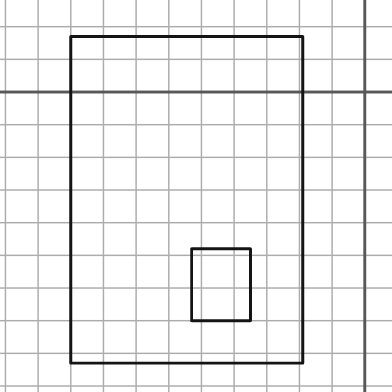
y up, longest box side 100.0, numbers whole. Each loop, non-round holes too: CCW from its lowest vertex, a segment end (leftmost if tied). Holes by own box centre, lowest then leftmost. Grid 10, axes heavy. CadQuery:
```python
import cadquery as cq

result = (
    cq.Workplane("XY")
    .moveTo(-90.0, -83.0)
    .lineTo(-19.0, -83.0)
    .lineTo(-19.0, 17.0)
    .lineTo(-90.0, 17.0)
    .close()
    .moveTo(-53.0, -70.0)
    .lineTo(-35.0, -70.0)
    .lineTo(-35.0, -48.0)
    .lineTo(-53.0, -48.0)
    .close()
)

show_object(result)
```